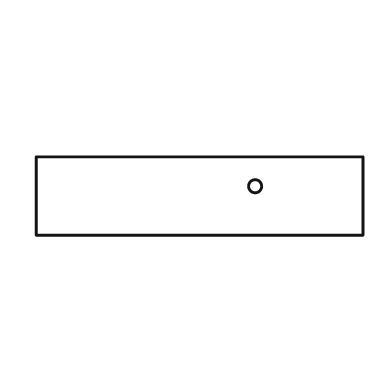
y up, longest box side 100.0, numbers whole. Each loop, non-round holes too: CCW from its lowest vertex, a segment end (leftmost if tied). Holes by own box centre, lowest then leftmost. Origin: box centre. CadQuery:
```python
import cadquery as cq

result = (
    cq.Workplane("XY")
    .moveTo(-50.0, -12.0)
    .lineTo(50.0, -12.0)
    .lineTo(50.0, 12.0)
    .lineTo(-50.0, 12.0)
    .close()
    .moveTo(17.0, 3.0)
    .circle(2.0)
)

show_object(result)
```